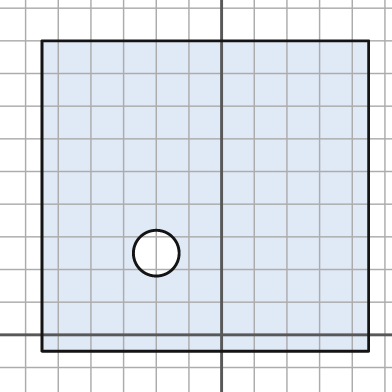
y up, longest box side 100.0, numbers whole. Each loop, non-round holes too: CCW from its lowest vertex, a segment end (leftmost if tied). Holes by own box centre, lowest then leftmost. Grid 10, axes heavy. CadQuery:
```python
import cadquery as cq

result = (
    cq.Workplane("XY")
    .moveTo(-55.0, -5.0)
    .lineTo(45.0, -5.0)
    .lineTo(45.0, 90.0)
    .lineTo(-55.0, 90.0)
    .close()
    .moveTo(-20.0, 25.0)
    .circle(7.0)
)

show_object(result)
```